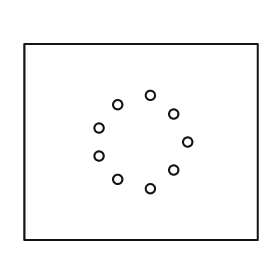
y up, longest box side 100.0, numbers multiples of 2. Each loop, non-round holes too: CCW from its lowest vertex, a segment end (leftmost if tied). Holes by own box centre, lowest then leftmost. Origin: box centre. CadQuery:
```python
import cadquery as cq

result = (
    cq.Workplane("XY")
    .moveTo(-50.0, -42.0)
    .lineTo(50.0, -42.0)
    .lineTo(50.0, 42.0)
    .lineTo(-50.0, 42.0)
    .close()
    .moveTo(4.0, -20.0)
    .circle(2.0)
    .moveTo(-10.0, -16.0)
    .circle(2.0)
    .moveTo(14.0, -12.0)
    .circle(2.0)
    .moveTo(-18.0, -6.0)
    .circle(2.0)
    .moveTo(20.0, 0.0)
    .circle(2.0)
    .moveTo(-18.0, 6.0)
    .circle(2.0)
    .moveTo(14.0, 12.0)
    .circle(2.0)
    .moveTo(-10.0, 16.0)
    .circle(2.0)
    .moveTo(4.0, 20.0)
    .circle(2.0)
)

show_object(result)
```